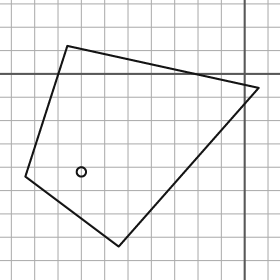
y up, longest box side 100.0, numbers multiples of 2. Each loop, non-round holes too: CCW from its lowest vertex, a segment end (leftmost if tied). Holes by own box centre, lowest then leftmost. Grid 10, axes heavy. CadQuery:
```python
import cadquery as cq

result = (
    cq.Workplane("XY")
    .moveTo(-54.0, -74.0)
    .lineTo(6.0, -6.0)
    .lineTo(-76.0, 12.0)
    .lineTo(-94.0, -44.0)
    .close()
    .moveTo(-70.0, -42.0)
    .circle(2.0)
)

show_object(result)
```